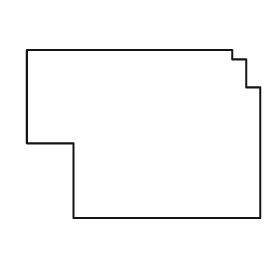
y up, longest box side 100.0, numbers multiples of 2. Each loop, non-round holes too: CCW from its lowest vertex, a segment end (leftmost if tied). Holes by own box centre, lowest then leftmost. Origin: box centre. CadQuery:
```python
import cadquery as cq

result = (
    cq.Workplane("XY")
    .moveTo(-30.0, -36.0)
    .lineTo(50.0, -36.0)
    .lineTo(50.0, 20.0)
    .lineTo(44.0, 20.0)
    .lineTo(44.0, 32.0)
    .lineTo(38.0, 32.0)
    .lineTo(38.0, 36.0)
    .lineTo(-50.0, 36.0)
    .lineTo(-50.0, -4.0)
    .lineTo(-30.0, -4.0)
    .close()
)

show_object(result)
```